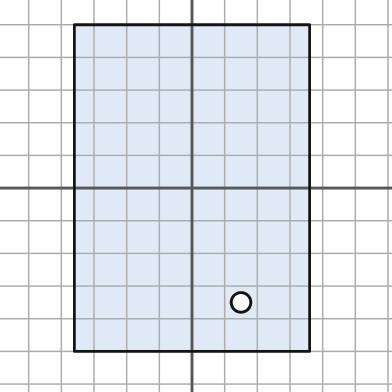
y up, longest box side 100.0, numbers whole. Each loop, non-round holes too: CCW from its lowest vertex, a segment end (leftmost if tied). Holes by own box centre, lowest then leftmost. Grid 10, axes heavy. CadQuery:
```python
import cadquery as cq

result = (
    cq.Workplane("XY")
    .moveTo(-36.0, -50.0)
    .lineTo(36.0, -50.0)
    .lineTo(36.0, 50.0)
    .lineTo(-36.0, 50.0)
    .close()
    .moveTo(15.0, -35.0)
    .circle(3.0)
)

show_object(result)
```